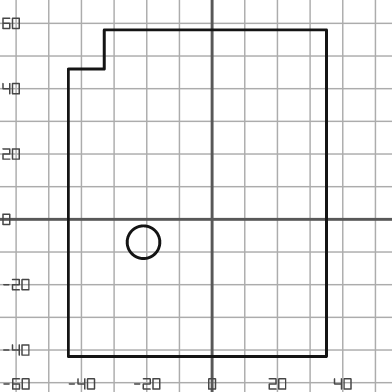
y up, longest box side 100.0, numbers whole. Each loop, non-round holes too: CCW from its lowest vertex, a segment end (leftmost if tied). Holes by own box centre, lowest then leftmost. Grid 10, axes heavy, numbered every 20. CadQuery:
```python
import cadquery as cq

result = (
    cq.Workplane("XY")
    .moveTo(-44.0, -42.0)
    .lineTo(35.0, -42.0)
    .lineTo(35.0, 58.0)
    .lineTo(-33.0, 58.0)
    .lineTo(-33.0, 46.0)
    .lineTo(-44.0, 46.0)
    .close()
    .moveTo(-21.0, -7.0)
    .circle(5.0)
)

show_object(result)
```